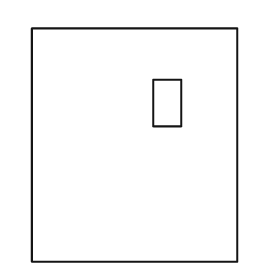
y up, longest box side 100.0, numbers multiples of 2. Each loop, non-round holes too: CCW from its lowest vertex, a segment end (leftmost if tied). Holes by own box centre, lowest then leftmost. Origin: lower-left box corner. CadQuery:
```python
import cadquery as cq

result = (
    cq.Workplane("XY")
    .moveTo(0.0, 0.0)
    .lineTo(88.0, 0.0)
    .lineTo(88.0, 100.0)
    .lineTo(0.0, 100.0)
    .close()
    .moveTo(52.0, 58.0)
    .lineTo(64.0, 58.0)
    .lineTo(64.0, 78.0)
    .lineTo(52.0, 78.0)
    .close()
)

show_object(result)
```